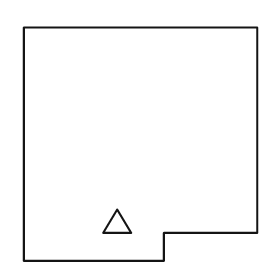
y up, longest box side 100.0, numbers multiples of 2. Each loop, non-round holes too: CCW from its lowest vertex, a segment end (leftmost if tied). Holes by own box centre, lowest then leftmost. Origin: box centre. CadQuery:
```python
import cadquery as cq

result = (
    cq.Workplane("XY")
    .moveTo(-50.0, -50.0)
    .lineTo(10.0, -50.0)
    .lineTo(10.0, -38.0)
    .lineTo(50.0, -38.0)
    .lineTo(50.0, 50.0)
    .lineTo(-50.0, 50.0)
    .close()
    .moveTo(-16.0, -38.0)
    .lineTo(-4.0, -38.0)
    .lineTo(-10.0, -28.0)
    .close()
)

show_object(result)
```